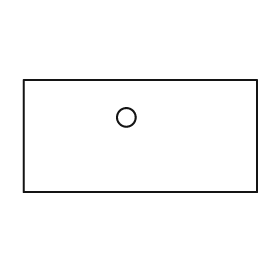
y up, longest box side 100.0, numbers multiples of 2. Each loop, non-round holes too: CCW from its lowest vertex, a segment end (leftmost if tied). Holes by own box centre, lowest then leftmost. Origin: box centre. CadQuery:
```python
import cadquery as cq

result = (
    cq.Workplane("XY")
    .moveTo(-50.0, -24.0)
    .lineTo(50.0, -24.0)
    .lineTo(50.0, 24.0)
    .lineTo(-50.0, 24.0)
    .close()
    .moveTo(-6.0, 8.0)
    .circle(4.0)
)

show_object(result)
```